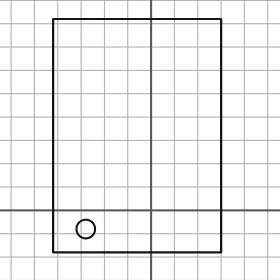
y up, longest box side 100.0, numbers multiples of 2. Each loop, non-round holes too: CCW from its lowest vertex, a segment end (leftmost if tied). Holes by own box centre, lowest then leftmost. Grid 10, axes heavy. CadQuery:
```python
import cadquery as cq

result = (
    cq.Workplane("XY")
    .moveTo(-42.0, -18.0)
    .lineTo(30.0, -18.0)
    .lineTo(30.0, 82.0)
    .lineTo(-42.0, 82.0)
    .close()
    .moveTo(-28.0, -8.0)
    .circle(4.0)
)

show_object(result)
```